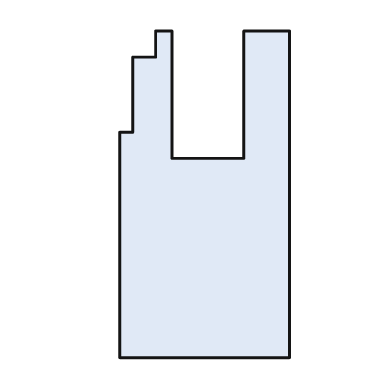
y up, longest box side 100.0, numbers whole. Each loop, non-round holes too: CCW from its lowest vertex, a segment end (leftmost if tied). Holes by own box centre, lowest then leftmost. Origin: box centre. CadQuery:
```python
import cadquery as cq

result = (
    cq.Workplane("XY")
    .moveTo(-26.0, -50.0)
    .lineTo(26.0, -50.0)
    .lineTo(26.0, 50.0)
    .lineTo(12.0, 50.0)
    .lineTo(12.0, 11.0)
    .lineTo(-10.0, 11.0)
    .lineTo(-10.0, 50.0)
    .lineTo(-15.0, 50.0)
    .lineTo(-15.0, 42.0)
    .lineTo(-22.0, 42.0)
    .lineTo(-22.0, 19.0)
    .lineTo(-26.0, 19.0)
    .close()
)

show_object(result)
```